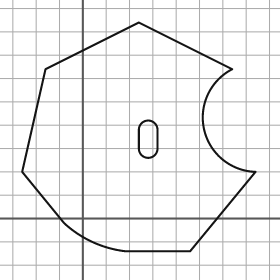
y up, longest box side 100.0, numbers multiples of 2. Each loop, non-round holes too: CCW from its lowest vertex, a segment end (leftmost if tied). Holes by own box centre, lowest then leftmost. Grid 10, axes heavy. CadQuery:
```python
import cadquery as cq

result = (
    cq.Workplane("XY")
    .moveTo(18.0, -14.0)
    .lineTo(46.0, -14.0)
    .lineTo(74.0, 20.0)
    .threePointArc((52.0, 38.0), (64.0, 64.0))
    .lineTo(24.0, 84.0)
    .lineTo(-16.0, 64.0)
    .lineTo(-26.0, 20.0)
    .lineTo(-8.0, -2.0)
    .threePointArc((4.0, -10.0), (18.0, -14.0))
    .close()
    .moveTo(24.0, 30.0)
    .threePointArc((28.0, 26.0), (32.0, 30.0))
    .lineTo(32.0, 38.0)
    .threePointArc((28.0, 42.0), (24.0, 38.0))
    .close()
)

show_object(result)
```